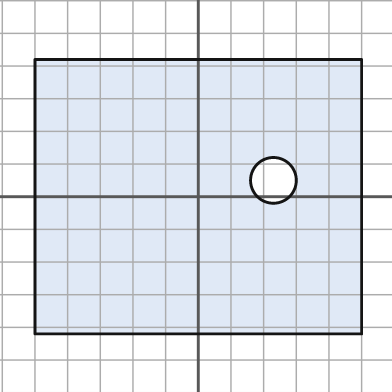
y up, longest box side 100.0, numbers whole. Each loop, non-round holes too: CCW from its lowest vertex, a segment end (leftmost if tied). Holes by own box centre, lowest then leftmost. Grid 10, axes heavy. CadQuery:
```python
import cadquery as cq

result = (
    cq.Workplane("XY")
    .moveTo(-50.0, -42.0)
    .lineTo(50.0, -42.0)
    .lineTo(50.0, 42.0)
    .lineTo(-50.0, 42.0)
    .close()
    .moveTo(23.0, 5.0)
    .circle(7.0)
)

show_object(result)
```